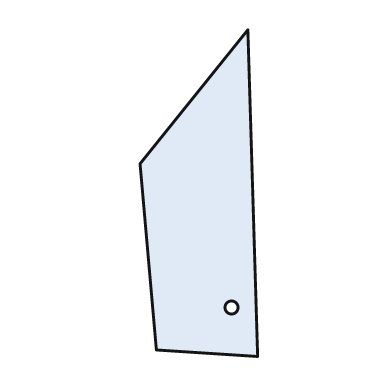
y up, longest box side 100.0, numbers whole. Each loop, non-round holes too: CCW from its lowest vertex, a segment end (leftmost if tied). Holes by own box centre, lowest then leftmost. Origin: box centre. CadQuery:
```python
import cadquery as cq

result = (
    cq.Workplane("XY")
    .moveTo(18.0, -50.0)
    .lineTo(15.0, 50.0)
    .lineTo(-18.0, 9.0)
    .lineTo(-13.0, -48.0)
    .close()
    .moveTo(10.0, -35.0)
    .circle(2.0)
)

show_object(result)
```